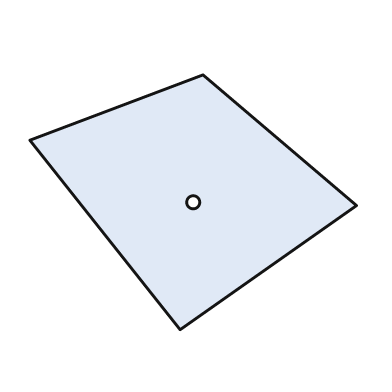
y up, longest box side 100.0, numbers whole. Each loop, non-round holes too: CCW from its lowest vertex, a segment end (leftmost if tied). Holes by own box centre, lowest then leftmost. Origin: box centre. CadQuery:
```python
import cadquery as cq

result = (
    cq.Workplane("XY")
    .moveTo(-4.0, -39.0)
    .lineTo(50.0, -1.0)
    .lineTo(3.0, 39.0)
    .lineTo(-50.0, 19.0)
    .close()
    .moveTo(0.0, 0.0)
    .circle(2.0)
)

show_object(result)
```